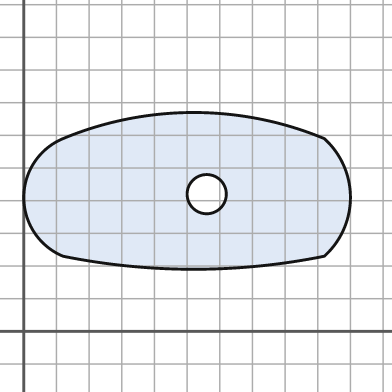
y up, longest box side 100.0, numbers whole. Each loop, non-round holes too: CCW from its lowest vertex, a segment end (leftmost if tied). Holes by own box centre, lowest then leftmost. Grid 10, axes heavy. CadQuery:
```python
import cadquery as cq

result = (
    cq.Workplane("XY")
    .moveTo(12.0, 23.0)
    .threePointArc((52.0, 19.0), (92.0, 23.0))
    .threePointArc((100.0, 41.0), (92.0, 59.0))
    .threePointArc((52.0, 67.0), (12.0, 59.0))
    .threePointArc((0.0, 41.0), (12.0, 23.0))
    .close()
    .moveTo(56.0, 42.0)
    .circle(6.0)
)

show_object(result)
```